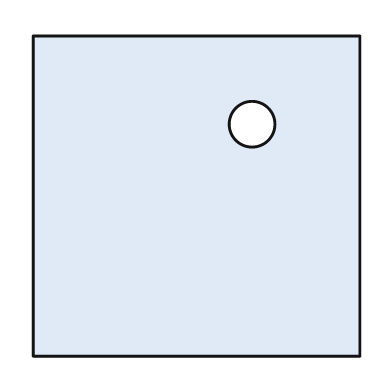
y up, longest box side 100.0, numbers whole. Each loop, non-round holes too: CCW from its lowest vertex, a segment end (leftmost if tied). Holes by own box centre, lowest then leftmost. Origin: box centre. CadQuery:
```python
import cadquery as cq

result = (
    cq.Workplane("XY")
    .moveTo(-50.0, -49.0)
    .lineTo(50.0, -49.0)
    .lineTo(50.0, 49.0)
    .lineTo(-50.0, 49.0)
    .close()
    .moveTo(17.0, 22.0)
    .circle(7.0)
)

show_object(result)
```